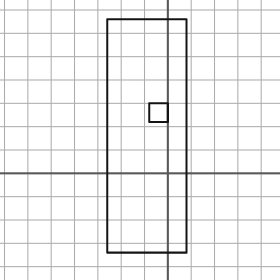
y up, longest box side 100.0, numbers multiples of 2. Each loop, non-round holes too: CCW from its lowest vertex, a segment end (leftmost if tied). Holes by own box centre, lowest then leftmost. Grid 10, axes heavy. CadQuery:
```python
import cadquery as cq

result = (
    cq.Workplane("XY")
    .moveTo(-26.0, -34.0)
    .lineTo(8.0, -34.0)
    .lineTo(8.0, 66.0)
    .lineTo(-26.0, 66.0)
    .close()
    .moveTo(-8.0, 22.0)
    .lineTo(0.0, 22.0)
    .lineTo(0.0, 30.0)
    .lineTo(-8.0, 30.0)
    .close()
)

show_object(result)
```